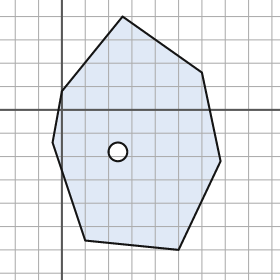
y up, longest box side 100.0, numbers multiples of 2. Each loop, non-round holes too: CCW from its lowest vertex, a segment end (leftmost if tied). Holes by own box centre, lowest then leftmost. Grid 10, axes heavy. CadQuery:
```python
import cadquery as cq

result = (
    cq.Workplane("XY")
    .moveTo(50.0, -60.0)
    .lineTo(68.0, -22.0)
    .lineTo(60.0, 16.0)
    .lineTo(26.0, 40.0)
    .lineTo(0.0, 8.0)
    .lineTo(-4.0, -14.0)
    .lineTo(10.0, -56.0)
    .close()
    .moveTo(24.0, -18.0)
    .circle(4.0)
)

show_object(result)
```